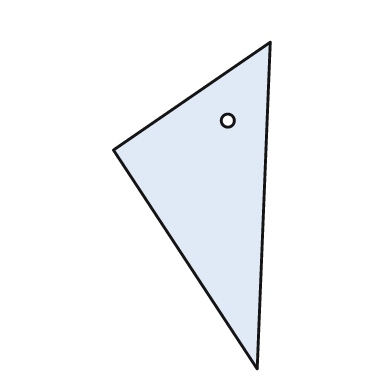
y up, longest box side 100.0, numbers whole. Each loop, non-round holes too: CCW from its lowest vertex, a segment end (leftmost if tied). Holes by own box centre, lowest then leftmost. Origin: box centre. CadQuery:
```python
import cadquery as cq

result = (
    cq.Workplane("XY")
    .moveTo(20.0, -50.0)
    .lineTo(24.0, 50.0)
    .lineTo(-24.0, 17.0)
    .close()
    .moveTo(11.0, 26.0)
    .circle(2.0)
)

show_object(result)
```